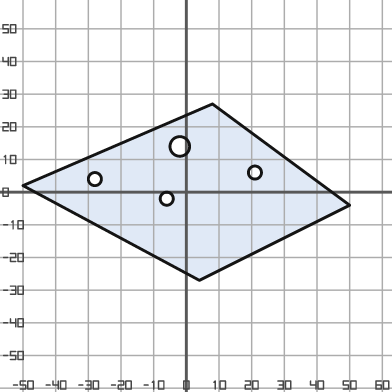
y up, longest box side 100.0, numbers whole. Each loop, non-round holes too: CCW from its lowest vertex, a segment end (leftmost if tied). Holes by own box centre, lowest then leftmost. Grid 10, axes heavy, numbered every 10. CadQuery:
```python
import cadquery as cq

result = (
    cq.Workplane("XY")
    .moveTo(4.0, -27.0)
    .lineTo(50.0, -4.0)
    .lineTo(8.0, 27.0)
    .lineTo(-50.0, 2.0)
    .close()
    .moveTo(-6.0, -2.0)
    .circle(2.0)
    .moveTo(-28.0, 4.0)
    .circle(2.0)
    .moveTo(21.0, 6.0)
    .circle(2.0)
    .moveTo(-2.0, 14.0)
    .circle(3.0)
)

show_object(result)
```